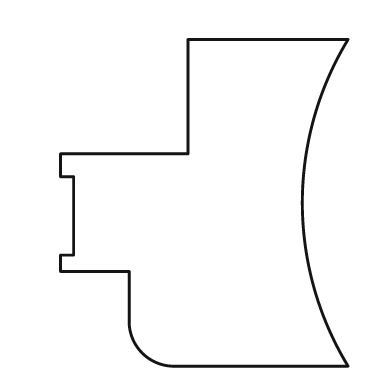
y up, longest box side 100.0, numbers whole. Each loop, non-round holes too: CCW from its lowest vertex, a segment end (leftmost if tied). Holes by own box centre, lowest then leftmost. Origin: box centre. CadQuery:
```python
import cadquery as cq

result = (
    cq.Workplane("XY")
    .moveTo(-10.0, -50.0)
    .lineTo(44.0, -50.0)
    .threePointArc((30.0, 0.0), (44.0, 50.0))
    .lineTo(-5.0, 50.0)
    .lineTo(-5.0, 15.0)
    .lineTo(-44.0, 15.0)
    .lineTo(-44.0, 8.0)
    .lineTo(-40.0, 8.0)
    .lineTo(-40.0, -16.0)
    .lineTo(-44.0, -16.0)
    .lineTo(-44.0, -21.0)
    .lineTo(-23.0, -21.0)
    .lineTo(-23.0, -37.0)
    .threePointArc((-19.0, -46.0), (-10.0, -50.0))
    .close()
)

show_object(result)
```